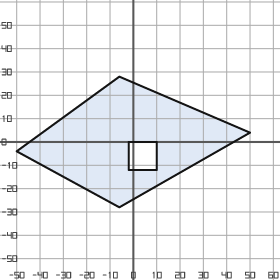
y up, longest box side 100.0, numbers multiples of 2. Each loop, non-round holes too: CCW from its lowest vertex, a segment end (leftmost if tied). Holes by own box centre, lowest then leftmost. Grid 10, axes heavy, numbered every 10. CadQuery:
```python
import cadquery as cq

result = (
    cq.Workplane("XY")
    .moveTo(-6.0, -28.0)
    .lineTo(50.0, 4.0)
    .lineTo(-6.0, 28.0)
    .lineTo(-50.0, -4.0)
    .close()
    .moveTo(-2.0, -12.0)
    .lineTo(10.0, -12.0)
    .lineTo(10.0, 0.0)
    .lineTo(-2.0, 0.0)
    .close()
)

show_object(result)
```